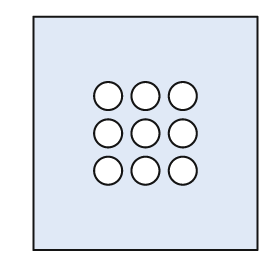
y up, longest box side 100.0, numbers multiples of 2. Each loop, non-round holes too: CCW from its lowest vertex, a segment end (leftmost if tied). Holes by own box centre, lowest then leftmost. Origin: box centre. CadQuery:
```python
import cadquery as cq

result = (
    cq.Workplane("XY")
    .moveTo(-48.0, -50.0)
    .lineTo(48.0, -50.0)
    .lineTo(48.0, 50.0)
    .lineTo(-48.0, 50.0)
    .close()
    .moveTo(-16.0, -16.0)
    .circle(6.0)
    .moveTo(0.0, -16.0)
    .circle(6.0)
    .moveTo(16.0, -16.0)
    .circle(6.0)
    .moveTo(-16.0, 0.0)
    .circle(6.0)
    .moveTo(0.0, 0.0)
    .circle(6.0)
    .moveTo(16.0, 0.0)
    .circle(6.0)
    .moveTo(-16.0, 16.0)
    .circle(6.0)
    .moveTo(0.0, 16.0)
    .circle(6.0)
    .moveTo(16.0, 16.0)
    .circle(6.0)
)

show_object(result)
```